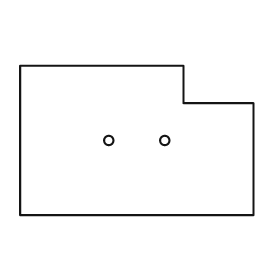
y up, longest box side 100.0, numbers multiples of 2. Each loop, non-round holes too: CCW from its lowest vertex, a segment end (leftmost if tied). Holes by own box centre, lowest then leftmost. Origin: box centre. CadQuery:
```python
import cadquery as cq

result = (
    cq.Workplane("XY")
    .moveTo(-50.0, -32.0)
    .lineTo(50.0, -32.0)
    .lineTo(50.0, 16.0)
    .lineTo(20.0, 16.0)
    .lineTo(20.0, 32.0)
    .lineTo(-50.0, 32.0)
    .close()
    .moveTo(-12.0, 0.0)
    .circle(2.0)
    .moveTo(12.0, 0.0)
    .circle(2.0)
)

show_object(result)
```